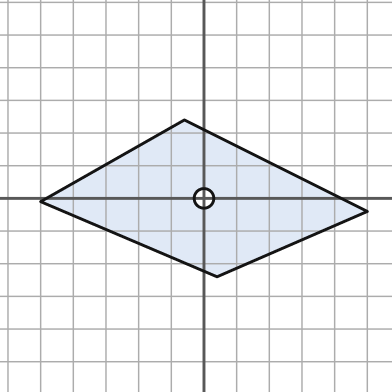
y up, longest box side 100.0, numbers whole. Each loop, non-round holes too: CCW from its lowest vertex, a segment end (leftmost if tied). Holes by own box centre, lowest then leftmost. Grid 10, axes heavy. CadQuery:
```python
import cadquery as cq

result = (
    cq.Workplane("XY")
    .moveTo(4.0, -24.0)
    .lineTo(50.0, -4.0)
    .lineTo(-6.0, 24.0)
    .lineTo(-50.0, -1.0)
    .close()
    .moveTo(0.0, 0.0)
    .circle(3.0)
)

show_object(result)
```